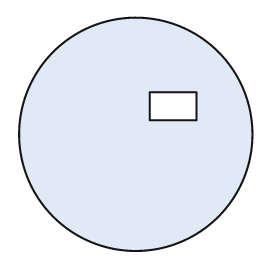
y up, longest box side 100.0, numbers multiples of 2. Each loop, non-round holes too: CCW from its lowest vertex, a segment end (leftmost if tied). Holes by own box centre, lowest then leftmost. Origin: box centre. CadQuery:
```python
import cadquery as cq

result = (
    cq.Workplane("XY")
    .moveTo(0.0, 0.0)
    .circle(50.0)
    .moveTo(6.0, 6.0)
    .lineTo(26.0, 6.0)
    .lineTo(26.0, 18.0)
    .lineTo(6.0, 18.0)
    .close()
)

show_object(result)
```